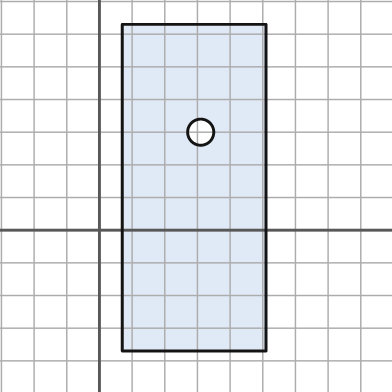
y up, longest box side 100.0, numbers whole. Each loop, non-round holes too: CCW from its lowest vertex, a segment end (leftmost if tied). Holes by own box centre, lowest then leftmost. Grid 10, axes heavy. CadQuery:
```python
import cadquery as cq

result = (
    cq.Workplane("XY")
    .moveTo(7.0, -37.0)
    .lineTo(51.0, -37.0)
    .lineTo(51.0, 63.0)
    .lineTo(7.0, 63.0)
    .close()
    .moveTo(31.0, 30.0)
    .circle(4.0)
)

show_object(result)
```